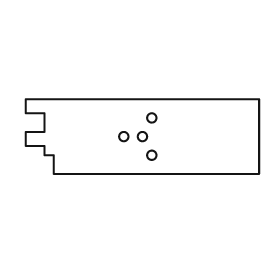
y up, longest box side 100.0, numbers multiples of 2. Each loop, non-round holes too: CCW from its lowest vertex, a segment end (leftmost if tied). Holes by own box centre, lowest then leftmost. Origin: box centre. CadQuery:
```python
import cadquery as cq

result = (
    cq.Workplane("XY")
    .moveTo(-38.0, -16.0)
    .lineTo(50.0, -16.0)
    .lineTo(50.0, 16.0)
    .lineTo(-50.0, 16.0)
    .lineTo(-50.0, 10.0)
    .lineTo(-42.0, 10.0)
    .lineTo(-42.0, 2.0)
    .lineTo(-50.0, 2.0)
    .lineTo(-50.0, -4.0)
    .lineTo(-42.0, -4.0)
    .lineTo(-42.0, -8.0)
    .lineTo(-38.0, -8.0)
    .close()
    .moveTo(4.0, -8.0)
    .circle(2.0)
    .moveTo(-8.0, 0.0)
    .circle(2.0)
    .moveTo(0.0, 0.0)
    .circle(2.0)
    .moveTo(4.0, 8.0)
    .circle(2.0)
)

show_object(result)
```